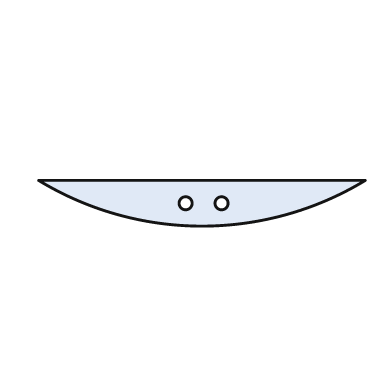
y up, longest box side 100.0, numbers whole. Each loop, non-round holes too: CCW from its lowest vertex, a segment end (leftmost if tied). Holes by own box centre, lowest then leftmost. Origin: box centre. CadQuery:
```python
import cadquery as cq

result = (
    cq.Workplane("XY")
    .moveTo(-50.0, 7.0)
    .threePointArc((0.0, -7.0), (50.0, 7.0))
    .close()
    .moveTo(-5.0, 0.0)
    .circle(2.0)
    .moveTo(6.0, 0.0)
    .circle(2.0)
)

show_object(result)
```